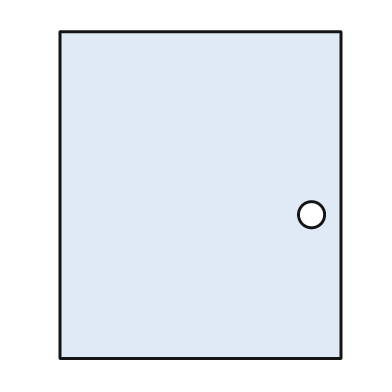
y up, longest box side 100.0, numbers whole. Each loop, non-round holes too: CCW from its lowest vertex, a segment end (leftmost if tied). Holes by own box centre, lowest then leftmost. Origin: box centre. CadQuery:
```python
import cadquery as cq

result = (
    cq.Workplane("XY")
    .moveTo(-43.0, -50.0)
    .lineTo(43.0, -50.0)
    .lineTo(43.0, 50.0)
    .lineTo(-43.0, 50.0)
    .close()
    .moveTo(34.0, -6.0)
    .circle(4.0)
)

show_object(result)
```